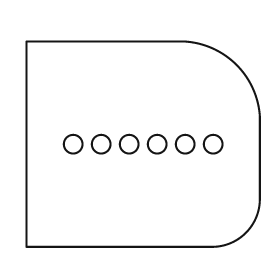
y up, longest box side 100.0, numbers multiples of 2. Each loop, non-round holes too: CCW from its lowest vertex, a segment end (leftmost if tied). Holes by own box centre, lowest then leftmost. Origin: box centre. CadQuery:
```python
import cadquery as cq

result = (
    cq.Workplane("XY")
    .moveTo(-50.0, -44.0)
    .lineTo(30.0, -44.0)
    .threePointArc((44.0, -38.0), (50.0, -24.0))
    .lineTo(50.0, 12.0)
    .threePointArc((40.0, 34.0), (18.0, 44.0))
    .lineTo(-50.0, 44.0)
    .close()
    .moveTo(-30.0, 0.0)
    .circle(4.0)
    .moveTo(-18.0, 0.0)
    .circle(4.0)
    .moveTo(-6.0, 0.0)
    .circle(4.0)
    .moveTo(6.0, 0.0)
    .circle(4.0)
    .moveTo(18.0, 0.0)
    .circle(4.0)
    .moveTo(30.0, 0.0)
    .circle(4.0)
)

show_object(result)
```